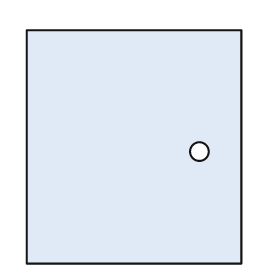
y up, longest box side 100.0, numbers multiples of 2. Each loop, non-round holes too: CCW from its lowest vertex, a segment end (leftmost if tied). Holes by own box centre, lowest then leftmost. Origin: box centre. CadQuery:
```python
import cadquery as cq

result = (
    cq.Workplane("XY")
    .moveTo(-46.0, -50.0)
    .lineTo(46.0, -50.0)
    .lineTo(46.0, 50.0)
    .lineTo(-46.0, 50.0)
    .close()
    .moveTo(28.0, -2.0)
    .circle(4.0)
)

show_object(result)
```